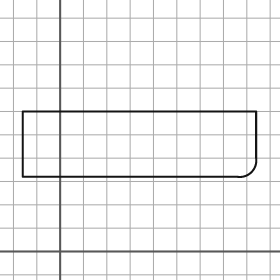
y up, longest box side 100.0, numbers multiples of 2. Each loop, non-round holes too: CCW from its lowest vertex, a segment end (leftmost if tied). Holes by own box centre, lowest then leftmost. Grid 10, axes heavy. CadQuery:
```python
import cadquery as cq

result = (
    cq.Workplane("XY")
    .moveTo(-16.0, 32.0)
    .lineTo(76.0, 32.0)
    .threePointArc((82.0, 34.0), (84.0, 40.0))
    .lineTo(84.0, 60.0)
    .lineTo(-16.0, 60.0)
    .close()
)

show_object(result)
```